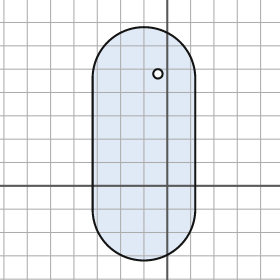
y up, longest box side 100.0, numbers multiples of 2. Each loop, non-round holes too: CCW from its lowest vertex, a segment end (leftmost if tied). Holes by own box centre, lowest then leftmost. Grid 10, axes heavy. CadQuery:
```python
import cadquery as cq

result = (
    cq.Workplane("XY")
    .moveTo(-32.0, -10.0)
    .threePointArc((-10.0, -32.0), (12.0, -10.0))
    .lineTo(12.0, 46.0)
    .threePointArc((-10.0, 68.0), (-32.0, 46.0))
    .close()
    .moveTo(-4.0, 48.0)
    .circle(2.0)
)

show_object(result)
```